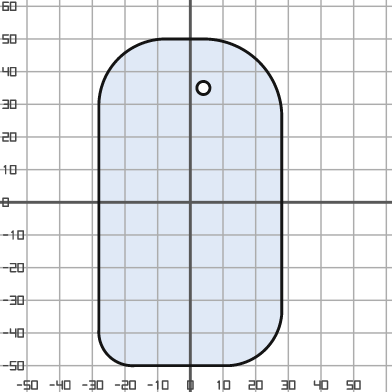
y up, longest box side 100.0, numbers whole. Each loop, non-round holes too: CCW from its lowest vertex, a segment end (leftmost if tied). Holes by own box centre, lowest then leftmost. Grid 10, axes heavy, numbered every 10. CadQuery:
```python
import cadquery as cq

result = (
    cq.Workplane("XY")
    .moveTo(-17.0, -50.0)
    .lineTo(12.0, -50.0)
    .threePointArc((23.0, -45.0), (28.0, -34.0))
    .lineTo(28.0, 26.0)
    .threePointArc((21.0, 43.0), (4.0, 50.0))
    .lineTo(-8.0, 50.0)
    .threePointArc((-22.0, 44.0), (-28.0, 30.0))
    .lineTo(-28.0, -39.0)
    .threePointArc((-25.0, -47.0), (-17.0, -50.0))
    .close()
    .moveTo(4.0, 35.0)
    .circle(2.0)
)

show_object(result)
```